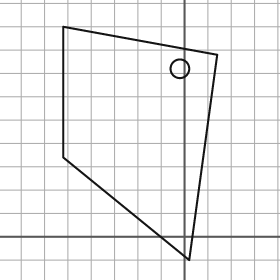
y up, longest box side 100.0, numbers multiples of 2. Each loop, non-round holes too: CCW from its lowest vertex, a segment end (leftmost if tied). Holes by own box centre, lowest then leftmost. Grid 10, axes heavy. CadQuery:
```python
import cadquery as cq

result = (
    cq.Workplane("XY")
    .moveTo(2.0, -10.0)
    .lineTo(14.0, 78.0)
    .lineTo(-52.0, 90.0)
    .lineTo(-52.0, 34.0)
    .close()
    .moveTo(-2.0, 72.0)
    .circle(4.0)
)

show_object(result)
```